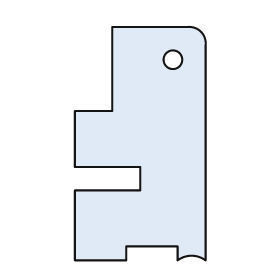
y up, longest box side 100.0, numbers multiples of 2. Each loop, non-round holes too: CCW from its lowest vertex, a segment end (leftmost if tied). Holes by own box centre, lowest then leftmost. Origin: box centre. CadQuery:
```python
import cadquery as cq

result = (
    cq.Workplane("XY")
    .moveTo(-28.0, -50.0)
    .lineTo(-6.0, -50.0)
    .lineTo(-6.0, -44.0)
    .lineTo(16.0, -44.0)
    .lineTo(16.0, -50.0)
    .threePointArc((22.0, -48.0), (28.0, -50.0))
    .lineTo(28.0, 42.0)
    .threePointArc((26.0, 48.0), (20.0, 50.0))
    .lineTo(-12.0, 50.0)
    .lineTo(-12.0, 14.0)
    .lineTo(-28.0, 14.0)
    .lineTo(-28.0, -10.0)
    .lineTo(0.0, -10.0)
    .lineTo(0.0, -20.0)
    .lineTo(-28.0, -20.0)
    .close()
    .moveTo(14.0, 36.0)
    .circle(4.0)
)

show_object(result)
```